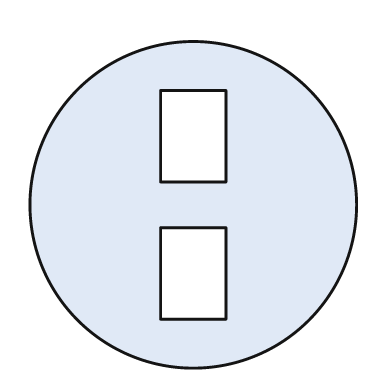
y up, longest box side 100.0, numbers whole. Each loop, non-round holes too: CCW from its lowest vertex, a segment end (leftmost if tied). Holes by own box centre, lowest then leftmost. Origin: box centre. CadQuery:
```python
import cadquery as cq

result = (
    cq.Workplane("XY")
    .moveTo(0.0, 0.0)
    .circle(50.0)
    .moveTo(-10.0, -35.0)
    .lineTo(10.0, -35.0)
    .lineTo(10.0, -7.0)
    .lineTo(-10.0, -7.0)
    .close()
    .moveTo(-10.0, 7.0)
    .lineTo(10.0, 7.0)
    .lineTo(10.0, 35.0)
    .lineTo(-10.0, 35.0)
    .close()
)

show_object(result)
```